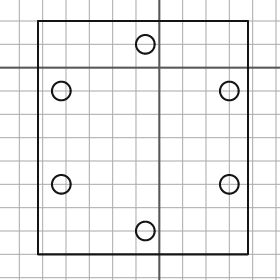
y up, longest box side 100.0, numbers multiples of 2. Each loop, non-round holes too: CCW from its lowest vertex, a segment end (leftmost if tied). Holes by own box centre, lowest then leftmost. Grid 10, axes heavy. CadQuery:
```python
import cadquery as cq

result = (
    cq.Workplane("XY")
    .moveTo(-52.0, -80.0)
    .lineTo(38.0, -80.0)
    .lineTo(38.0, 20.0)
    .lineTo(-52.0, 20.0)
    .close()
    .moveTo(-6.0, -70.0)
    .circle(4.0)
    .moveTo(-42.0, -50.0)
    .circle(4.0)
    .moveTo(30.0, -50.0)
    .circle(4.0)
    .moveTo(-42.0, -10.0)
    .circle(4.0)
    .moveTo(30.0, -10.0)
    .circle(4.0)
    .moveTo(-6.0, 10.0)
    .circle(4.0)
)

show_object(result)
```